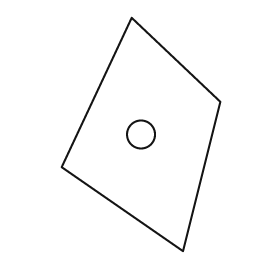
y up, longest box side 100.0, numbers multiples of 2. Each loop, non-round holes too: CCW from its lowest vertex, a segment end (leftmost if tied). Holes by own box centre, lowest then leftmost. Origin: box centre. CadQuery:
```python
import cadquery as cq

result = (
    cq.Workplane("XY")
    .moveTo(18.0, -50.0)
    .lineTo(34.0, 14.0)
    .lineTo(-4.0, 50.0)
    .lineTo(-34.0, -14.0)
    .close()
    .moveTo(0.0, 0.0)
    .circle(6.0)
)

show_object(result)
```